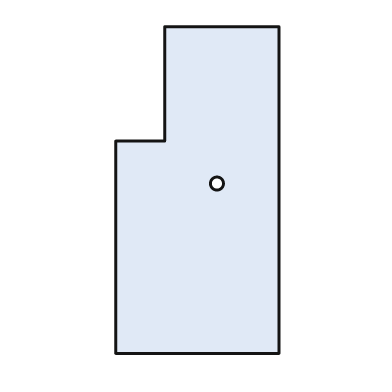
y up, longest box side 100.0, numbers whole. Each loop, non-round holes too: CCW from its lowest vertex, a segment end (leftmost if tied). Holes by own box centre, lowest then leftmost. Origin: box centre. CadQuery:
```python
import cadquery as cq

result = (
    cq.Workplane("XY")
    .moveTo(-25.0, -50.0)
    .lineTo(25.0, -50.0)
    .lineTo(25.0, 50.0)
    .lineTo(-10.0, 50.0)
    .lineTo(-10.0, 15.0)
    .lineTo(-25.0, 15.0)
    .close()
    .moveTo(6.0, 2.0)
    .circle(2.0)
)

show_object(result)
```